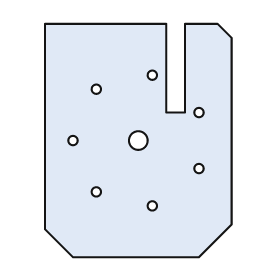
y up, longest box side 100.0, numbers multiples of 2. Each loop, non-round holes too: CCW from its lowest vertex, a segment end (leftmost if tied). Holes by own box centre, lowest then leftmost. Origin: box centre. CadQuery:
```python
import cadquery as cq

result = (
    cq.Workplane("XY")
    .moveTo(-28.0, -50.0)
    .lineTo(26.0, -50.0)
    .lineTo(40.0, -36.0)
    .lineTo(40.0, 44.0)
    .lineTo(34.0, 50.0)
    .lineTo(20.0, 50.0)
    .lineTo(20.0, 12.0)
    .lineTo(12.0, 12.0)
    .lineTo(12.0, 50.0)
    .lineTo(-40.0, 50.0)
    .lineTo(-40.0, -38.0)
    .close()
    .moveTo(6.0, -28.0)
    .circle(2.0)
    .moveTo(-18.0, -22.0)
    .circle(2.0)
    .moveTo(26.0, -12.0)
    .circle(2.0)
    .moveTo(-28.0, 0.0)
    .circle(2.0)
    .moveTo(0.0, 0.0)
    .circle(4.0)
    .moveTo(26.0, 12.0)
    .circle(2.0)
    .moveTo(-18.0, 22.0)
    .circle(2.0)
    .moveTo(6.0, 28.0)
    .circle(2.0)
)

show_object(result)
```